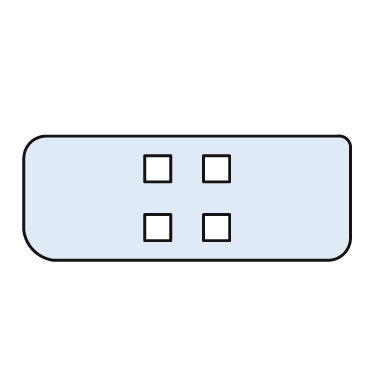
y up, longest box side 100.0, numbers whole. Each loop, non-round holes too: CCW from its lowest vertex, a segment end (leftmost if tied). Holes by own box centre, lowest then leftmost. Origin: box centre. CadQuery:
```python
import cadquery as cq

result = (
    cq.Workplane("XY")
    .moveTo(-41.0, -19.0)
    .lineTo(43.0, -19.0)
    .threePointArc((48.0, -17.0), (50.0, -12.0))
    .lineTo(50.0, 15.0)
    .threePointArc((49.0, 18.0), (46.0, 19.0))
    .lineTo(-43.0, 19.0)
    .threePointArc((-48.0, 17.0), (-50.0, 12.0))
    .lineTo(-50.0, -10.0)
    .threePointArc((-47.0, -16.0), (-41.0, -19.0))
    .close()
    .moveTo(-13.0, -13.0)
    .lineTo(-5.0, -13.0)
    .lineTo(-5.0, -5.0)
    .lineTo(-13.0, -5.0)
    .close()
    .moveTo(5.0, -13.0)
    .lineTo(13.0, -13.0)
    .lineTo(13.0, -5.0)
    .lineTo(5.0, -5.0)
    .close()
    .moveTo(-13.0, 5.0)
    .lineTo(-5.0, 5.0)
    .lineTo(-5.0, 13.0)
    .lineTo(-13.0, 13.0)
    .close()
    .moveTo(5.0, 5.0)
    .lineTo(13.0, 5.0)
    .lineTo(13.0, 13.0)
    .lineTo(5.0, 13.0)
    .close()
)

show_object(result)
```